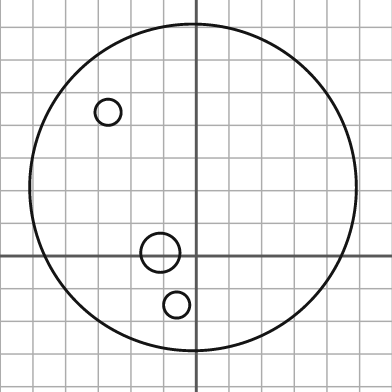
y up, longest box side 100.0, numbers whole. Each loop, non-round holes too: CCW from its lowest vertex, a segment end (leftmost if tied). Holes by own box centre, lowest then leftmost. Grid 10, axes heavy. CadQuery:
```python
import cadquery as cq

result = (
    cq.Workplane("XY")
    .moveTo(-1.0, 21.0)
    .circle(50.0)
    .moveTo(-6.0, -15.0)
    .circle(4.0)
    .moveTo(-11.0, 1.0)
    .circle(6.0)
    .moveTo(-27.0, 44.0)
    .circle(4.0)
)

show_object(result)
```